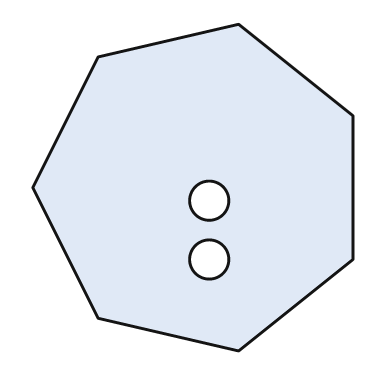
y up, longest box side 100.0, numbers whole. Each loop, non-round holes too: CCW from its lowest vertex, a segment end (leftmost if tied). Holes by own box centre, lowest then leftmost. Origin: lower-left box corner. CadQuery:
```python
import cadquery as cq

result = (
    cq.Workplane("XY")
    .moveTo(63.0, 0.0)
    .lineTo(98.0, 28.0)
    .lineTo(98.0, 72.0)
    .lineTo(63.0, 100.0)
    .lineTo(20.0, 90.0)
    .lineTo(0.0, 50.0)
    .lineTo(20.0, 10.0)
    .close()
    .moveTo(54.0, 28.0)
    .circle(6.0)
    .moveTo(54.0, 46.0)
    .circle(6.0)
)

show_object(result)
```